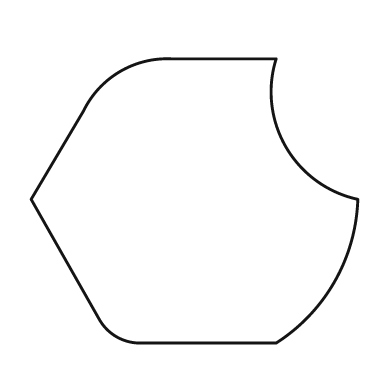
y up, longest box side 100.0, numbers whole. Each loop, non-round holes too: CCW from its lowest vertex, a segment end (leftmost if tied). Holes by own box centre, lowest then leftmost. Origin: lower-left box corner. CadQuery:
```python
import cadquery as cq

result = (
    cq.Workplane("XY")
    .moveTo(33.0, 0.0)
    .lineTo(75.0, 0.0)
    .threePointArc((93.0, 19.0), (100.0, 44.0))
    .threePointArc((78.0, 60.0), (75.0, 87.0))
    .lineTo(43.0, 87.0)
    .threePointArc((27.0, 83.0), (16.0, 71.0))
    .lineTo(0.0, 44.0)
    .lineTo(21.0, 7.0)
    .threePointArc((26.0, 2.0), (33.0, 0.0))
    .close()
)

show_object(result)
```